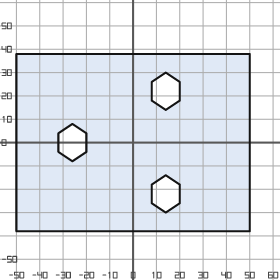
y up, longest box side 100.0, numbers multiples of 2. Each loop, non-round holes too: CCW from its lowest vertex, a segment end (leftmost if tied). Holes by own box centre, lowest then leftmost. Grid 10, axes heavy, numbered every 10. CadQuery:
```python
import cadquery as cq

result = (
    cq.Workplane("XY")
    .moveTo(-50.0, -38.0)
    .lineTo(50.0, -38.0)
    .lineTo(50.0, 38.0)
    .lineTo(-50.0, 38.0)
    .close()
    .moveTo(14.0, -30.0)
    .lineTo(20.0, -26.0)
    .lineTo(20.0, -18.0)
    .lineTo(14.0, -14.0)
    .lineTo(8.0, -18.0)
    .lineTo(8.0, -26.0)
    .close()
    .moveTo(-26.0, -8.0)
    .lineTo(-20.0, -4.0)
    .lineTo(-20.0, 4.0)
    .lineTo(-26.0, 8.0)
    .lineTo(-32.0, 4.0)
    .lineTo(-32.0, -4.0)
    .close()
    .moveTo(14.0, 14.0)
    .lineTo(20.0, 18.0)
    .lineTo(20.0, 26.0)
    .lineTo(14.0, 30.0)
    .lineTo(8.0, 26.0)
    .lineTo(8.0, 18.0)
    .close()
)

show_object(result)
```